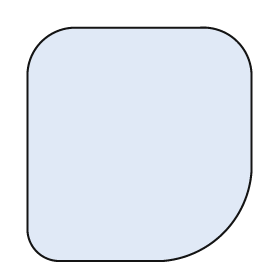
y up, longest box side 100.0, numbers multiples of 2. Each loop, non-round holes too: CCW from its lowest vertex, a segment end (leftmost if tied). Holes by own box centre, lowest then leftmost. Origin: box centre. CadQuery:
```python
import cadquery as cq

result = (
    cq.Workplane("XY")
    .moveTo(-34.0, -50.0)
    .lineTo(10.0, -50.0)
    .threePointArc((36.0, -38.0), (48.0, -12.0))
    .lineTo(48.0, 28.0)
    .threePointArc((42.0, 44.0), (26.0, 50.0))
    .lineTo(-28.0, 50.0)
    .threePointArc((-42.0, 44.0), (-48.0, 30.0))
    .lineTo(-48.0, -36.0)
    .threePointArc((-44.0, -46.0), (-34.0, -50.0))
    .close()
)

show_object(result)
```